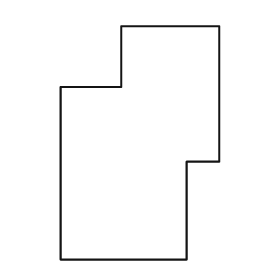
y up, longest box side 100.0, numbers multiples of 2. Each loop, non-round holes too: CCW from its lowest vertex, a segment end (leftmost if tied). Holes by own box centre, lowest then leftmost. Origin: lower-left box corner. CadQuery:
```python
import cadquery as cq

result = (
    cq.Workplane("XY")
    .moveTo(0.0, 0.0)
    .lineTo(54.0, 0.0)
    .lineTo(54.0, 42.0)
    .lineTo(68.0, 42.0)
    .lineTo(68.0, 100.0)
    .lineTo(26.0, 100.0)
    .lineTo(26.0, 74.0)
    .lineTo(0.0, 74.0)
    .close()
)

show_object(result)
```